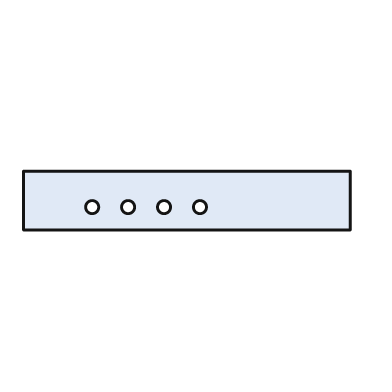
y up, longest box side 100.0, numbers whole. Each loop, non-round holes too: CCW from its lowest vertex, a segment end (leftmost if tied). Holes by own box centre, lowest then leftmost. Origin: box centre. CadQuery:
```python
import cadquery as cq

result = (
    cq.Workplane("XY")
    .moveTo(-50.0, -9.0)
    .lineTo(50.0, -9.0)
    .lineTo(50.0, 9.0)
    .lineTo(-50.0, 9.0)
    .close()
    .moveTo(-29.0, -2.0)
    .circle(2.0)
    .moveTo(-18.0, -2.0)
    .circle(2.0)
    .moveTo(-7.0, -2.0)
    .circle(2.0)
    .moveTo(4.0, -2.0)
    .circle(2.0)
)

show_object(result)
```